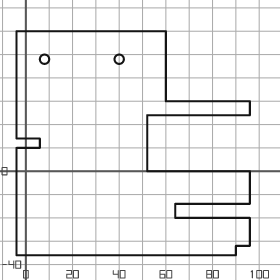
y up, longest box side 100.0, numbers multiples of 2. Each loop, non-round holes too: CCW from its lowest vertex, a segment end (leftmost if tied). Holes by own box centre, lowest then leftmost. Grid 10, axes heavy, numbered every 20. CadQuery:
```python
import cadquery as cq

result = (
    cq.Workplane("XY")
    .moveTo(-4.0, -36.0)
    .lineTo(90.0, -36.0)
    .lineTo(90.0, -32.0)
    .lineTo(96.0, -32.0)
    .lineTo(96.0, -20.0)
    .lineTo(64.0, -20.0)
    .lineTo(64.0, -14.0)
    .lineTo(96.0, -14.0)
    .lineTo(96.0, 0.0)
    .lineTo(52.0, 0.0)
    .lineTo(52.0, 24.0)
    .lineTo(96.0, 24.0)
    .lineTo(96.0, 30.0)
    .lineTo(60.0, 30.0)
    .lineTo(60.0, 60.0)
    .lineTo(-4.0, 60.0)
    .lineTo(-4.0, 14.0)
    .lineTo(6.0, 14.0)
    .lineTo(6.0, 10.0)
    .lineTo(-4.0, 10.0)
    .close()
    .moveTo(8.0, 48.0)
    .circle(2.0)
    .moveTo(40.0, 48.0)
    .circle(2.0)
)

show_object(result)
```